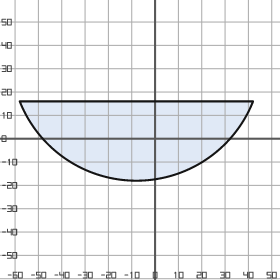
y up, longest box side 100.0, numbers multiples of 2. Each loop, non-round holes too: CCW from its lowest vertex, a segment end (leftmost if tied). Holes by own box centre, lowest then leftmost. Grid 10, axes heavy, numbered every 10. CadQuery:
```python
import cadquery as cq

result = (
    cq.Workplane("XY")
    .moveTo(-58.0, 16.0)
    .threePointArc((-8.0, -18.0), (42.0, 16.0))
    .close()
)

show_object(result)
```